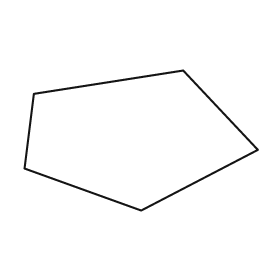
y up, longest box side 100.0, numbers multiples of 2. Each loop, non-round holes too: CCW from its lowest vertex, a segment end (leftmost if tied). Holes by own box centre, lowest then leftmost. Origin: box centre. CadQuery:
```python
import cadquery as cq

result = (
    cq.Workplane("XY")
    .moveTo(0.0, -30.0)
    .lineTo(50.0, -4.0)
    .lineTo(18.0, 30.0)
    .lineTo(-46.0, 20.0)
    .lineTo(-50.0, -12.0)
    .close()
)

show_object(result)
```